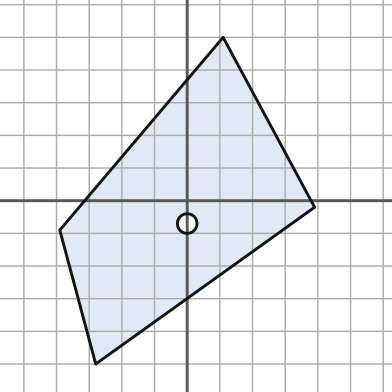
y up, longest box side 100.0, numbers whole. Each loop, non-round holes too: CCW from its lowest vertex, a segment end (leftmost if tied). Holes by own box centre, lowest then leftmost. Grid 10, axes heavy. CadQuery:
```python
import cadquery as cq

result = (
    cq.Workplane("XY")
    .moveTo(-28.0, -50.0)
    .lineTo(39.0, -2.0)
    .lineTo(11.0, 50.0)
    .lineTo(-39.0, -9.0)
    .close()
    .moveTo(0.0, -7.0)
    .circle(3.0)
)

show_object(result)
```